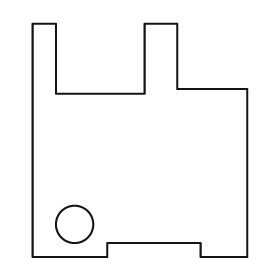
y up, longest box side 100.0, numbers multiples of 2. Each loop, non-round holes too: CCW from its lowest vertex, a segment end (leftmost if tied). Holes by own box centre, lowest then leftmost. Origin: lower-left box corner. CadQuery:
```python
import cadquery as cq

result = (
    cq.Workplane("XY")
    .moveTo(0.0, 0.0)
    .lineTo(32.0, 0.0)
    .lineTo(32.0, 6.0)
    .lineTo(72.0, 6.0)
    .lineTo(72.0, 0.0)
    .lineTo(92.0, 0.0)
    .lineTo(92.0, 72.0)
    .lineTo(62.0, 72.0)
    .lineTo(62.0, 100.0)
    .lineTo(48.0, 100.0)
    .lineTo(48.0, 70.0)
    .lineTo(10.0, 70.0)
    .lineTo(10.0, 100.0)
    .lineTo(0.0, 100.0)
    .close()
    .moveTo(18.0, 14.0)
    .circle(8.0)
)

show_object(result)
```